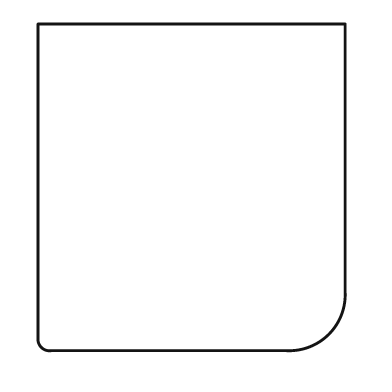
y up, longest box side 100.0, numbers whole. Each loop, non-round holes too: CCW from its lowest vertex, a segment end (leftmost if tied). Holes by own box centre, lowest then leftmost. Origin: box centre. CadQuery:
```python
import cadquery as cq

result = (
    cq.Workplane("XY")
    .moveTo(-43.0, -50.0)
    .lineTo(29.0, -50.0)
    .threePointArc((42.0, -45.0), (47.0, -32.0))
    .lineTo(47.0, 50.0)
    .lineTo(-47.0, 50.0)
    .lineTo(-47.0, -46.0)
    .threePointArc((-46.0, -49.0), (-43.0, -50.0))
    .close()
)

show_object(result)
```